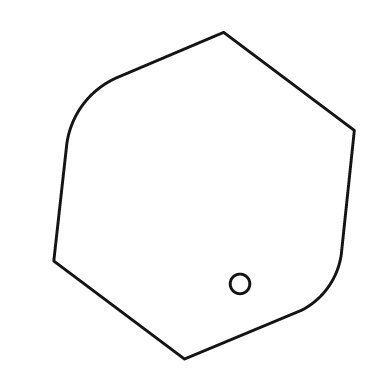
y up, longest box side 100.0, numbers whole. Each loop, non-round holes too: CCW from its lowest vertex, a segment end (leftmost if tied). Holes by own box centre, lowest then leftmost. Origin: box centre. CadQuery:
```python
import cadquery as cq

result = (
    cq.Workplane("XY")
    .moveTo(-6.0, -50.0)
    .lineTo(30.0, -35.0)
    .threePointArc((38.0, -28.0), (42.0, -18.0))
    .lineTo(46.0, 20.0)
    .lineTo(6.0, 50.0)
    .lineTo(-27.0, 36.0)
    .threePointArc((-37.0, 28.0), (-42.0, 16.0))
    .lineTo(-46.0, -20.0)
    .close()
    .moveTo(11.0, -27.0)
    .circle(3.0)
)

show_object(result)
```